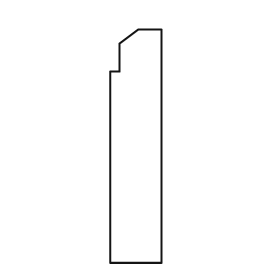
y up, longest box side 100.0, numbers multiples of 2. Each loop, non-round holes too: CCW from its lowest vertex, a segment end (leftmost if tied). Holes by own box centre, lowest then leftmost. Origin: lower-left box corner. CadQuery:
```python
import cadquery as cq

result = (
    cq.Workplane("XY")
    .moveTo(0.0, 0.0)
    .lineTo(22.0, 0.0)
    .lineTo(22.0, 100.0)
    .lineTo(12.0, 100.0)
    .lineTo(4.0, 94.0)
    .lineTo(4.0, 82.0)
    .lineTo(0.0, 82.0)
    .close()
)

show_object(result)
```